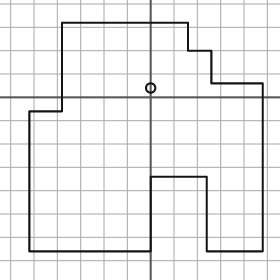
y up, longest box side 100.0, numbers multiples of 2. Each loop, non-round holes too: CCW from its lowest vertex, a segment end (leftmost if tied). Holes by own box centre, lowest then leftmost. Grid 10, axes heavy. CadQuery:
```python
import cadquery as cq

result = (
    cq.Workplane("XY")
    .moveTo(-52.0, -66.0)
    .lineTo(0.0, -66.0)
    .lineTo(0.0, -34.0)
    .lineTo(24.0, -34.0)
    .lineTo(24.0, -66.0)
    .lineTo(48.0, -66.0)
    .lineTo(48.0, 6.0)
    .lineTo(26.0, 6.0)
    .lineTo(26.0, 20.0)
    .lineTo(16.0, 20.0)
    .lineTo(16.0, 32.0)
    .lineTo(-38.0, 32.0)
    .lineTo(-38.0, -6.0)
    .lineTo(-52.0, -6.0)
    .close()
    .moveTo(0.0, 4.0)
    .circle(2.0)
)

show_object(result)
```